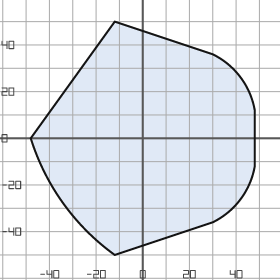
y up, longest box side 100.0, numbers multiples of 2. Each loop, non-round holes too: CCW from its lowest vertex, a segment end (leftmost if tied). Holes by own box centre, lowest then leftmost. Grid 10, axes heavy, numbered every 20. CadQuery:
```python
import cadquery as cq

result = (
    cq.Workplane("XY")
    .moveTo(-12.0, -50.0)
    .lineTo(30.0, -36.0)
    .threePointArc((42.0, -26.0), (48.0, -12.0))
    .lineTo(48.0, 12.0)
    .threePointArc((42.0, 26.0), (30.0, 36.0))
    .lineTo(-12.0, 50.0)
    .lineTo(-48.0, 0.0)
    .threePointArc((-34.0, -28.0), (-12.0, -50.0))
    .close()
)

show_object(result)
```